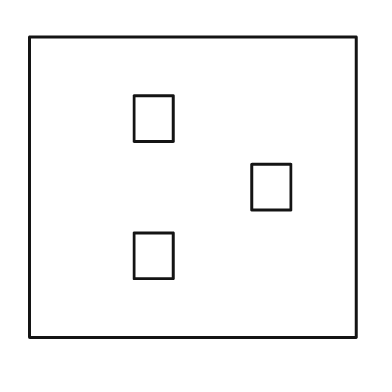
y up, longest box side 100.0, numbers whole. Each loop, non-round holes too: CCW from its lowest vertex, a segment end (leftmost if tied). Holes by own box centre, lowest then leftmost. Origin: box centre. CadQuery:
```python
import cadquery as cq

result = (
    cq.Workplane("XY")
    .moveTo(-50.0, -46.0)
    .lineTo(50.0, -46.0)
    .lineTo(50.0, 46.0)
    .lineTo(-50.0, 46.0)
    .close()
    .moveTo(-18.0, -28.0)
    .lineTo(-6.0, -28.0)
    .lineTo(-6.0, -14.0)
    .lineTo(-18.0, -14.0)
    .close()
    .moveTo(18.0, -7.0)
    .lineTo(30.0, -7.0)
    .lineTo(30.0, 7.0)
    .lineTo(18.0, 7.0)
    .close()
    .moveTo(-18.0, 14.0)
    .lineTo(-6.0, 14.0)
    .lineTo(-6.0, 28.0)
    .lineTo(-18.0, 28.0)
    .close()
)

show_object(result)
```